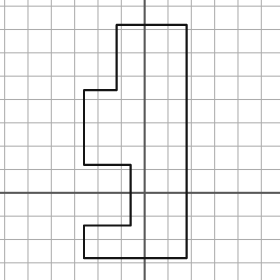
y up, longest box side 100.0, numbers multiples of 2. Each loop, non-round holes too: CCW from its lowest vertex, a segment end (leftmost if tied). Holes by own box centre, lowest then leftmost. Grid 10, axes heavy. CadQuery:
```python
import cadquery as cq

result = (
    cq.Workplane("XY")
    .moveTo(-26.0, -28.0)
    .lineTo(18.0, -28.0)
    .lineTo(18.0, 72.0)
    .lineTo(-12.0, 72.0)
    .lineTo(-12.0, 44.0)
    .lineTo(-26.0, 44.0)
    .lineTo(-26.0, 12.0)
    .lineTo(-6.0, 12.0)
    .lineTo(-6.0, -14.0)
    .lineTo(-26.0, -14.0)
    .close()
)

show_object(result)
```